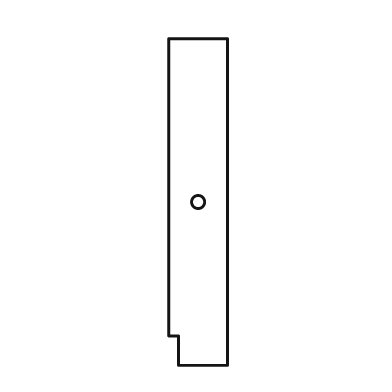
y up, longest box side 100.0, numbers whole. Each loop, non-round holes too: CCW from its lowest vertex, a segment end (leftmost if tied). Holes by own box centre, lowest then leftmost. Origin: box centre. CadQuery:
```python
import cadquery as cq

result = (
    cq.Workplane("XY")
    .moveTo(-6.0, -50.0)
    .lineTo(9.0, -50.0)
    .lineTo(9.0, 50.0)
    .lineTo(-9.0, 50.0)
    .lineTo(-9.0, -41.0)
    .lineTo(-6.0, -41.0)
    .close()
    .moveTo(0.0, 0.0)
    .circle(2.0)
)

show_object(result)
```